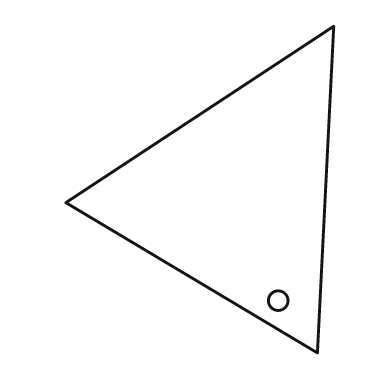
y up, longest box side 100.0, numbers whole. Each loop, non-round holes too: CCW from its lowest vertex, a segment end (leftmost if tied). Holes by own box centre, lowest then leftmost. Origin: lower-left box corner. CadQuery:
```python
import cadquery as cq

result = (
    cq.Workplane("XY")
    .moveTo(77.0, 0.0)
    .lineTo(82.0, 100.0)
    .lineTo(0.0, 46.0)
    .close()
    .moveTo(65.0, 16.0)
    .circle(3.0)
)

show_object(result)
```